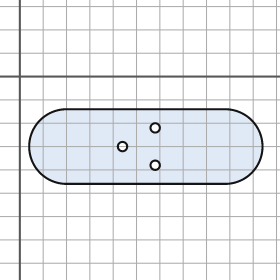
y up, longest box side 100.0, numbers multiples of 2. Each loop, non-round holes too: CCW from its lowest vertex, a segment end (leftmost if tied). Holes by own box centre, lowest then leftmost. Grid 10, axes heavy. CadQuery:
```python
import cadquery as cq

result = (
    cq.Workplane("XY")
    .moveTo(20.0, -46.0)
    .lineTo(88.0, -46.0)
    .threePointArc((104.0, -30.0), (88.0, -14.0))
    .lineTo(20.0, -14.0)
    .threePointArc((4.0, -30.0), (20.0, -46.0))
    .close()
    .moveTo(58.0, -38.0)
    .circle(2.0)
    .moveTo(44.0, -30.0)
    .circle(2.0)
    .moveTo(58.0, -22.0)
    .circle(2.0)
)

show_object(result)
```